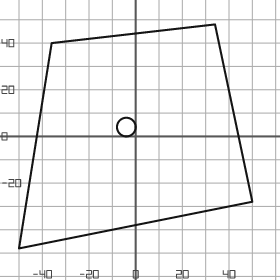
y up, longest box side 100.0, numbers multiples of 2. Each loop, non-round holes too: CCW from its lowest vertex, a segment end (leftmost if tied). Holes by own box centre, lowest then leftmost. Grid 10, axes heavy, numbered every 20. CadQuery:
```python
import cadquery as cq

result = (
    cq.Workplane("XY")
    .moveTo(-50.0, -48.0)
    .lineTo(50.0, -28.0)
    .lineTo(34.0, 48.0)
    .lineTo(-36.0, 40.0)
    .close()
    .moveTo(-4.0, 4.0)
    .circle(4.0)
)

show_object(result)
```